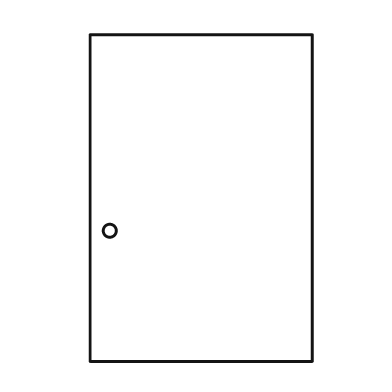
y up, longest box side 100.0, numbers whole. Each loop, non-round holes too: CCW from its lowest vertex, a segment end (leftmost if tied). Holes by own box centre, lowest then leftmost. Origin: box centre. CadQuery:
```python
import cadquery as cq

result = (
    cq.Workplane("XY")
    .moveTo(-34.0, -50.0)
    .lineTo(34.0, -50.0)
    .lineTo(34.0, 50.0)
    .lineTo(-34.0, 50.0)
    .close()
    .moveTo(-28.0, -10.0)
    .circle(2.0)
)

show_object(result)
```